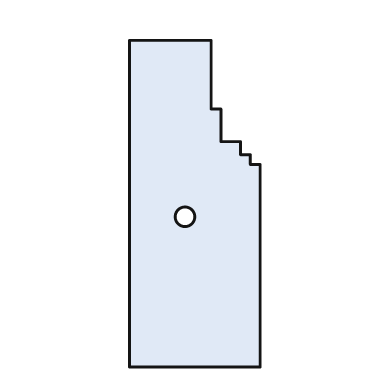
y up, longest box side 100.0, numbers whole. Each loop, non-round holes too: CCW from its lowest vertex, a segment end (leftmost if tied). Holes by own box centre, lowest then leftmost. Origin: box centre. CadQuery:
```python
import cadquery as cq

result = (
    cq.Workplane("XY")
    .moveTo(-20.0, -50.0)
    .lineTo(20.0, -50.0)
    .lineTo(20.0, 12.0)
    .lineTo(17.0, 12.0)
    .lineTo(17.0, 15.0)
    .lineTo(14.0, 15.0)
    .lineTo(14.0, 19.0)
    .lineTo(8.0, 19.0)
    .lineTo(8.0, 29.0)
    .lineTo(5.0, 29.0)
    .lineTo(5.0, 50.0)
    .lineTo(-20.0, 50.0)
    .close()
    .moveTo(-3.0, -4.0)
    .circle(3.0)
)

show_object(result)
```